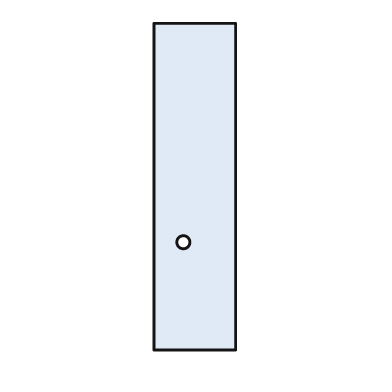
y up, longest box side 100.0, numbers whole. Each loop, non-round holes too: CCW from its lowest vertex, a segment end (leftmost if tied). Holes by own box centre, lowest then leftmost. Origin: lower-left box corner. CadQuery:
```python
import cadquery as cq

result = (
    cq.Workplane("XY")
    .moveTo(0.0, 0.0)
    .lineTo(25.0, 0.0)
    .lineTo(25.0, 100.0)
    .lineTo(0.0, 100.0)
    .close()
    .moveTo(9.0, 33.0)
    .circle(2.0)
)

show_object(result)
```